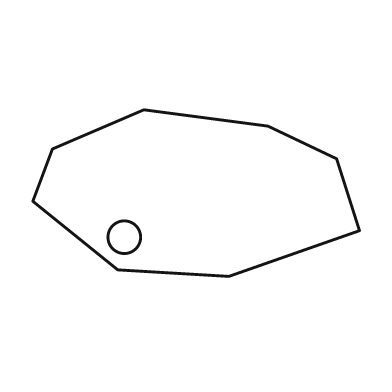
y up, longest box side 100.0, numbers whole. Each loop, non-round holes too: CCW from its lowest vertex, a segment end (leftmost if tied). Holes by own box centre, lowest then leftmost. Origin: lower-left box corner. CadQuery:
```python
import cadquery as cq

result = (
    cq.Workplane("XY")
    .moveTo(60.0, 0.0)
    .lineTo(100.0, 14.0)
    .lineTo(93.0, 36.0)
    .lineTo(72.0, 46.0)
    .lineTo(34.0, 51.0)
    .lineTo(6.0, 39.0)
    .lineTo(0.0, 23.0)
    .lineTo(26.0, 2.0)
    .close()
    .moveTo(28.0, 12.0)
    .circle(5.0)
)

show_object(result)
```